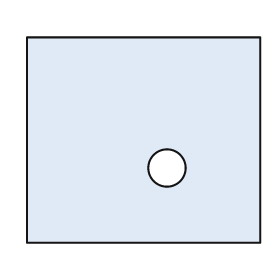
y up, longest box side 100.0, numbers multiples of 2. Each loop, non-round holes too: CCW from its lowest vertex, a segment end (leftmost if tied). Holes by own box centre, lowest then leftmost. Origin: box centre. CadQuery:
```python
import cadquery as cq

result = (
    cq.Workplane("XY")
    .moveTo(-50.0, -44.0)
    .lineTo(50.0, -44.0)
    .lineTo(50.0, 44.0)
    .lineTo(-50.0, 44.0)
    .close()
    .moveTo(10.0, -12.0)
    .circle(8.0)
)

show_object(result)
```